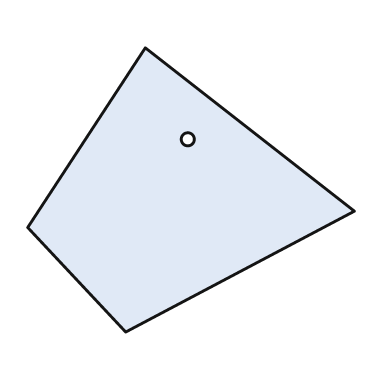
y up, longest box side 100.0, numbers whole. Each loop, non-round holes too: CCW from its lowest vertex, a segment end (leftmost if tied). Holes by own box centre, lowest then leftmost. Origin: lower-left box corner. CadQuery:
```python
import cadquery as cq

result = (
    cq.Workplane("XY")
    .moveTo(30.0, 0.0)
    .lineTo(100.0, 37.0)
    .lineTo(36.0, 87.0)
    .lineTo(0.0, 32.0)
    .close()
    .moveTo(49.0, 59.0)
    .circle(2.0)
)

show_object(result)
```